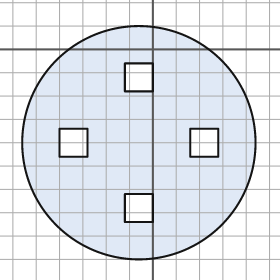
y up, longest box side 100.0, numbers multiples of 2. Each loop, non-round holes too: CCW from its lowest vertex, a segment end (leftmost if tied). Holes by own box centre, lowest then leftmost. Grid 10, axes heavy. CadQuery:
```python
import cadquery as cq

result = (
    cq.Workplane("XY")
    .moveTo(-6.0, -40.0)
    .circle(50.0)
    .moveTo(-12.0, -74.0)
    .lineTo(0.0, -74.0)
    .lineTo(0.0, -62.0)
    .lineTo(-12.0, -62.0)
    .close()
    .moveTo(-40.0, -46.0)
    .lineTo(-28.0, -46.0)
    .lineTo(-28.0, -34.0)
    .lineTo(-40.0, -34.0)
    .close()
    .moveTo(16.0, -46.0)
    .lineTo(28.0, -46.0)
    .lineTo(28.0, -34.0)
    .lineTo(16.0, -34.0)
    .close()
    .moveTo(-12.0, -18.0)
    .lineTo(0.0, -18.0)
    .lineTo(0.0, -6.0)
    .lineTo(-12.0, -6.0)
    .close()
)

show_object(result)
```